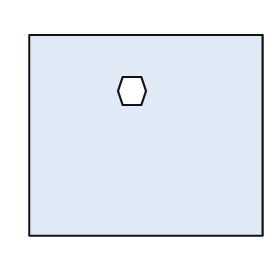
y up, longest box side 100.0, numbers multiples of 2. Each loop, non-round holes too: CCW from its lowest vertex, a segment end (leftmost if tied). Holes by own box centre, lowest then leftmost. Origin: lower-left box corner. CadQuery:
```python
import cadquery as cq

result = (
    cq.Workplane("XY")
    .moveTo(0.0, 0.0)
    .lineTo(100.0, 0.0)
    .lineTo(100.0, 86.0)
    .lineTo(0.0, 86.0)
    .close()
    .moveTo(40.0, 56.0)
    .lineTo(48.0, 56.0)
    .lineTo(50.0, 62.0)
    .lineTo(48.0, 68.0)
    .lineTo(40.0, 68.0)
    .lineTo(38.0, 62.0)
    .close()
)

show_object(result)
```